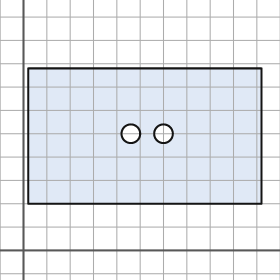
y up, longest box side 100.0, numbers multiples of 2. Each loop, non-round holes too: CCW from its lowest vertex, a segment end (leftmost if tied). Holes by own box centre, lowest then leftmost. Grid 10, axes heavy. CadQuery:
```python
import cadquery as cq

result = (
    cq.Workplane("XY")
    .moveTo(2.0, 20.0)
    .lineTo(102.0, 20.0)
    .lineTo(102.0, 78.0)
    .lineTo(2.0, 78.0)
    .close()
    .moveTo(46.0, 50.0)
    .circle(4.0)
    .moveTo(60.0, 50.0)
    .circle(4.0)
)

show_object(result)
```